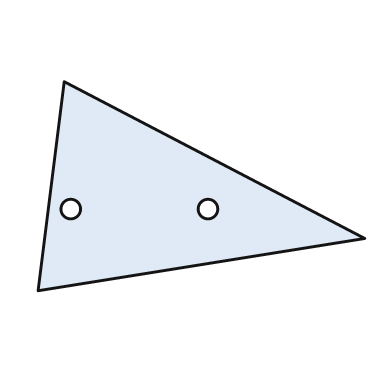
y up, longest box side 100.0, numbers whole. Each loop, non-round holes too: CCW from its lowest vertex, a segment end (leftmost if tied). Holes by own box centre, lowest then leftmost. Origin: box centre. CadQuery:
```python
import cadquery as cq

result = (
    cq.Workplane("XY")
    .moveTo(-50.0, -32.0)
    .lineTo(50.0, -16.0)
    .lineTo(-42.0, 32.0)
    .close()
    .moveTo(-40.0, -7.0)
    .circle(3.0)
    .moveTo(2.0, -7.0)
    .circle(3.0)
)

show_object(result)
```